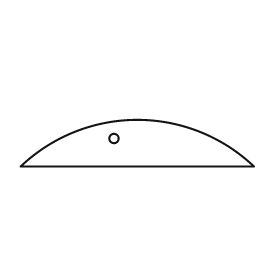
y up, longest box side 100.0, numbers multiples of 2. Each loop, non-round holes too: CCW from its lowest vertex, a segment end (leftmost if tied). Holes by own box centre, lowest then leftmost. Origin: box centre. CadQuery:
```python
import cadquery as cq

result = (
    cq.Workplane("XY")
    .moveTo(-50.0, -10.0)
    .lineTo(50.0, -10.0)
    .threePointArc((0.0, 10.0), (-50.0, -10.0))
    .close()
    .moveTo(-10.0, 2.0)
    .circle(2.0)
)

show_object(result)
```